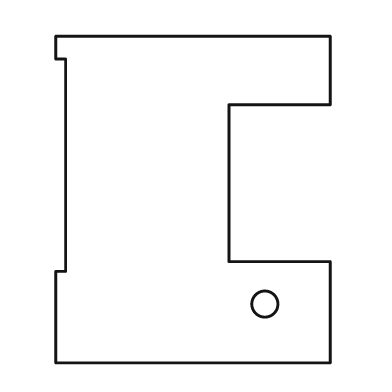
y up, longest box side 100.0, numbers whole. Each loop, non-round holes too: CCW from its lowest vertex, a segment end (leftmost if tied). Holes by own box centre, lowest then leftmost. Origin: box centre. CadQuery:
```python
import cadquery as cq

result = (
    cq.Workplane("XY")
    .moveTo(-42.0, -50.0)
    .lineTo(42.0, -50.0)
    .lineTo(42.0, -19.0)
    .lineTo(11.0, -19.0)
    .lineTo(11.0, 29.0)
    .lineTo(42.0, 29.0)
    .lineTo(42.0, 50.0)
    .lineTo(-42.0, 50.0)
    .lineTo(-42.0, 43.0)
    .lineTo(-39.0, 43.0)
    .lineTo(-39.0, -22.0)
    .lineTo(-42.0, -22.0)
    .close()
    .moveTo(22.0, -32.0)
    .circle(4.0)
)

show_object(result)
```